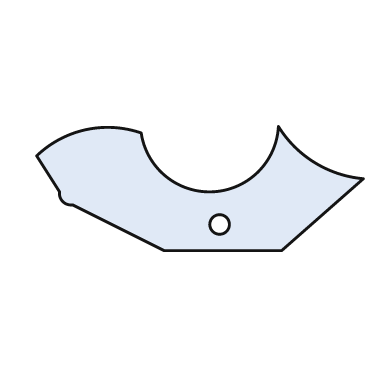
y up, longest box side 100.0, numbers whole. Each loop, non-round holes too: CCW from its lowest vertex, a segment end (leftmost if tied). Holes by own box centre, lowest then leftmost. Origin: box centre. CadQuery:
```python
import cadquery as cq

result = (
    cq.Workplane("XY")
    .moveTo(-11.0, -19.0)
    .lineTo(25.0, -19.0)
    .lineTo(50.0, 3.0)
    .threePointArc((35.0, 8.0), (24.0, 19.0))
    .threePointArc((4.0, -1.0), (-18.0, 17.0))
    .threePointArc((-35.0, 18.0), (-50.0, 10.0))
    .lineTo(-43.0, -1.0)
    .threePointArc((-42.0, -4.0), (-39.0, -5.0))
    .close()
    .moveTo(6.0, -11.0)
    .circle(3.0)
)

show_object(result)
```